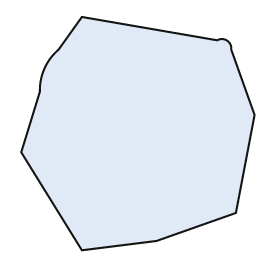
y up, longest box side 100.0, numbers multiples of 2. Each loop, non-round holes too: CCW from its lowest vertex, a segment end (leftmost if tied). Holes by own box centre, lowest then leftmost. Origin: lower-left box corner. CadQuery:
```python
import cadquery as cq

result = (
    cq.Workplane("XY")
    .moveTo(26.0, 0.0)
    .lineTo(58.0, 4.0)
    .lineTo(92.0, 16.0)
    .lineTo(100.0, 58.0)
    .lineTo(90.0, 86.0)
    .threePointArc((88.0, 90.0), (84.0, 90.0))
    .lineTo(26.0, 100.0)
    .lineTo(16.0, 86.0)
    .threePointArc((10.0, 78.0), (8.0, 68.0))
    .lineTo(0.0, 42.0)
    .close()
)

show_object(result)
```